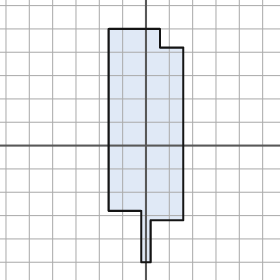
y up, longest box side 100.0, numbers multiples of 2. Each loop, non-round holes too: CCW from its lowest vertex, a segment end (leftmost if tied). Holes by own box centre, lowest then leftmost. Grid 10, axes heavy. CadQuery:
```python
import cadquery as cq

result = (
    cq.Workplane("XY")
    .moveTo(-2.0, -50.0)
    .lineTo(2.0, -50.0)
    .lineTo(2.0, -32.0)
    .lineTo(16.0, -32.0)
    .lineTo(16.0, 42.0)
    .lineTo(6.0, 42.0)
    .lineTo(6.0, 50.0)
    .lineTo(-16.0, 50.0)
    .lineTo(-16.0, -28.0)
    .lineTo(-2.0, -28.0)
    .close()
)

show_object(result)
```